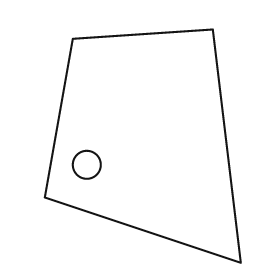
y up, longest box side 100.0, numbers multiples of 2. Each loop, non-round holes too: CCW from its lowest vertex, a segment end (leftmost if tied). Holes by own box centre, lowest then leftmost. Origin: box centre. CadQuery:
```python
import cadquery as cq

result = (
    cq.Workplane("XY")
    .moveTo(42.0, -50.0)
    .lineTo(30.0, 50.0)
    .lineTo(-30.0, 46.0)
    .lineTo(-42.0, -22.0)
    .close()
    .moveTo(-24.0, -8.0)
    .circle(6.0)
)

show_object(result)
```